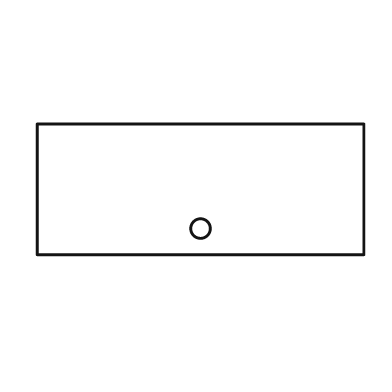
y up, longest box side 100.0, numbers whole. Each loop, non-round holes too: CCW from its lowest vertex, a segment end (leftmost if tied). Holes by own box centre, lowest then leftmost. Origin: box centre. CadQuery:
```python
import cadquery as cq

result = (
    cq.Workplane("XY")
    .moveTo(-50.0, -20.0)
    .lineTo(50.0, -20.0)
    .lineTo(50.0, 20.0)
    .lineTo(-50.0, 20.0)
    .close()
    .moveTo(0.0, -12.0)
    .circle(3.0)
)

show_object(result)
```